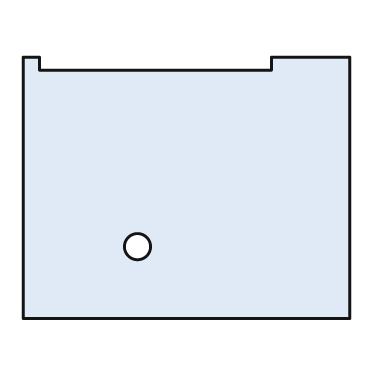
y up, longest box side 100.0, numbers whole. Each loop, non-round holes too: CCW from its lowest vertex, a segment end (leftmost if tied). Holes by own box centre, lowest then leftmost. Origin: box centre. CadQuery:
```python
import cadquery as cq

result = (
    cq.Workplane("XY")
    .moveTo(-50.0, -40.0)
    .lineTo(50.0, -40.0)
    .lineTo(50.0, 40.0)
    .lineTo(26.0, 40.0)
    .lineTo(26.0, 36.0)
    .lineTo(-45.0, 36.0)
    .lineTo(-45.0, 40.0)
    .lineTo(-50.0, 40.0)
    .close()
    .moveTo(-15.0, -18.0)
    .circle(4.0)
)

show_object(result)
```